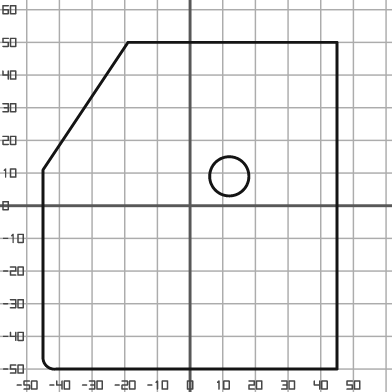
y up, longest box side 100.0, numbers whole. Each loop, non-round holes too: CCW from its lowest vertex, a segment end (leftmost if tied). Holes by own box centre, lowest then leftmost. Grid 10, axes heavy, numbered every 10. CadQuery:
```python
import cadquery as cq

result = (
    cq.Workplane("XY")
    .moveTo(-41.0, -50.0)
    .lineTo(45.0, -50.0)
    .lineTo(45.0, 50.0)
    .lineTo(-19.0, 50.0)
    .lineTo(-45.0, 11.0)
    .lineTo(-45.0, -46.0)
    .threePointArc((-44.0, -49.0), (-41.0, -50.0))
    .close()
    .moveTo(12.0, 9.0)
    .circle(6.0)
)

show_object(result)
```